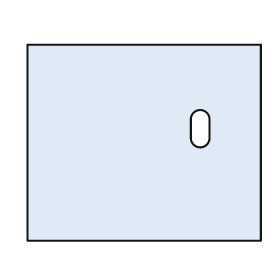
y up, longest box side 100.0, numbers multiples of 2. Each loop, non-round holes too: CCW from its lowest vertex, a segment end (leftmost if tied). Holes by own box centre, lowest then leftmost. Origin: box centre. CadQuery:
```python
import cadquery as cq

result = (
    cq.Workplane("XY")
    .moveTo(-50.0, -42.0)
    .lineTo(50.0, -42.0)
    .lineTo(50.0, 42.0)
    .lineTo(-50.0, 42.0)
    .close()
    .moveTo(20.0, 2.0)
    .threePointArc((24.0, -2.0), (28.0, 2.0))
    .lineTo(28.0, 10.0)
    .threePointArc((24.0, 14.0), (20.0, 10.0))
    .close()
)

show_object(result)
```